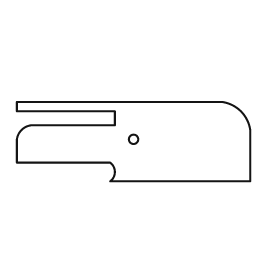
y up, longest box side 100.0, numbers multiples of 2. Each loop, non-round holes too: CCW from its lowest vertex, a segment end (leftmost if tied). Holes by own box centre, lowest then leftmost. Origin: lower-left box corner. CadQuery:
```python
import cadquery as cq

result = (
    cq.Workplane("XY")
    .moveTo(40.0, 0.0)
    .lineTo(100.0, 0.0)
    .lineTo(100.0, 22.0)
    .threePointArc((96.0, 30.0), (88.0, 34.0))
    .lineTo(0.0, 34.0)
    .lineTo(0.0, 30.0)
    .lineTo(42.0, 30.0)
    .lineTo(42.0, 24.0)
    .lineTo(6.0, 24.0)
    .threePointArc((2.0, 22.0), (0.0, 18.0))
    .lineTo(0.0, 8.0)
    .lineTo(40.0, 8.0)
    .threePointArc((42.0, 4.0), (40.0, 0.0))
    .close()
    .moveTo(50.0, 18.0)
    .circle(2.0)
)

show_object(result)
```